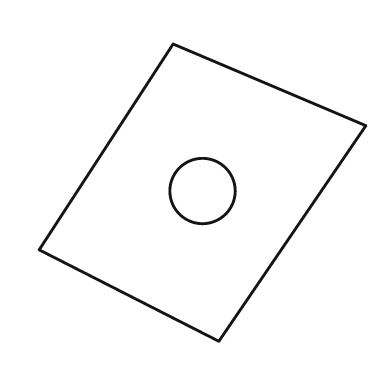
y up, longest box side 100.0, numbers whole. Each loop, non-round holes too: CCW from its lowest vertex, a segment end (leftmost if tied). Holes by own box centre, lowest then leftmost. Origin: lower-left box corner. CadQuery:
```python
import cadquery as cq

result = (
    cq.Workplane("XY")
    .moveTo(55.0, 0.0)
    .lineTo(100.0, 66.0)
    .lineTo(41.0, 91.0)
    .lineTo(0.0, 28.0)
    .close()
    .moveTo(50.0, 46.0)
    .circle(10.0)
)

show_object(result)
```